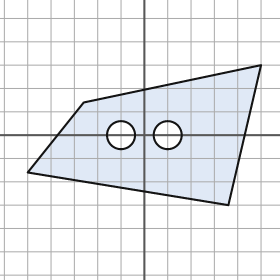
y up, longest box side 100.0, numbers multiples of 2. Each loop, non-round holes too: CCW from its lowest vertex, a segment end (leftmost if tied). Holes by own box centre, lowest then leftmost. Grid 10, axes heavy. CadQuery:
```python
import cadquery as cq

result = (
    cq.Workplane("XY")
    .moveTo(36.0, -30.0)
    .lineTo(50.0, 30.0)
    .lineTo(-26.0, 14.0)
    .lineTo(-50.0, -16.0)
    .close()
    .moveTo(-10.0, 0.0)
    .circle(6.0)
    .moveTo(10.0, 0.0)
    .circle(6.0)
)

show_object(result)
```